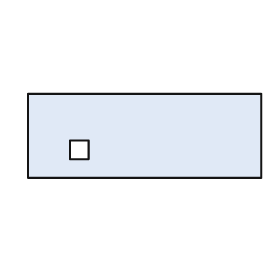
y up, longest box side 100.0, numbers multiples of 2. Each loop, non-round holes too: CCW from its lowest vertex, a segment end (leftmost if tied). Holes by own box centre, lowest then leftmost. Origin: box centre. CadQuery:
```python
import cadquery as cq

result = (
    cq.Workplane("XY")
    .moveTo(-50.0, -18.0)
    .lineTo(50.0, -18.0)
    .lineTo(50.0, 18.0)
    .lineTo(-50.0, 18.0)
    .close()
    .moveTo(-32.0, -10.0)
    .lineTo(-24.0, -10.0)
    .lineTo(-24.0, -2.0)
    .lineTo(-32.0, -2.0)
    .close()
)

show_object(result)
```